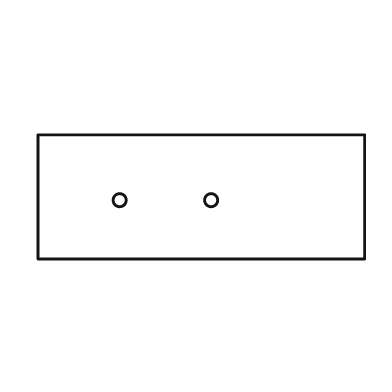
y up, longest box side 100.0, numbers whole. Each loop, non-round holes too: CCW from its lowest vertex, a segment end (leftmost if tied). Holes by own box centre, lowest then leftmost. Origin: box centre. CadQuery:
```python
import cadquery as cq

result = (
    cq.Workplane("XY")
    .moveTo(-50.0, -19.0)
    .lineTo(50.0, -19.0)
    .lineTo(50.0, 19.0)
    .lineTo(-50.0, 19.0)
    .close()
    .moveTo(-25.0, -1.0)
    .circle(2.0)
    .moveTo(3.0, -1.0)
    .circle(2.0)
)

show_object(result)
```